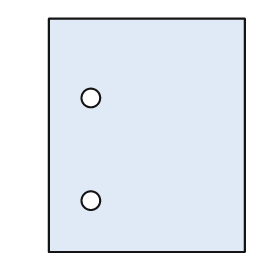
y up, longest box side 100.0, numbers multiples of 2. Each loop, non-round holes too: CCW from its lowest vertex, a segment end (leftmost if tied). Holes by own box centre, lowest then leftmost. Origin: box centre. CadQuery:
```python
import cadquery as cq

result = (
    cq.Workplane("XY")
    .moveTo(-42.0, -50.0)
    .lineTo(42.0, -50.0)
    .lineTo(42.0, 50.0)
    .lineTo(-42.0, 50.0)
    .close()
    .moveTo(-24.0, -28.0)
    .circle(4.0)
    .moveTo(-24.0, 16.0)
    .circle(4.0)
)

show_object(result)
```